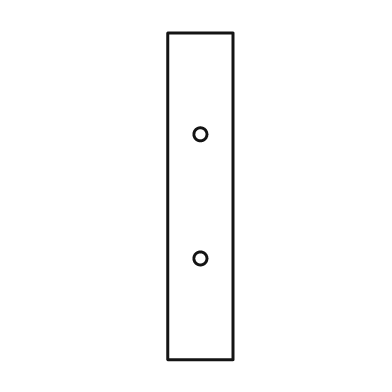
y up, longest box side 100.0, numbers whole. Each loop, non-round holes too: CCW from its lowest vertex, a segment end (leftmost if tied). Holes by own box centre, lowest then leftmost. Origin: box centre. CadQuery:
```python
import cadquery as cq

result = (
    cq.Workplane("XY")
    .moveTo(-10.0, -50.0)
    .lineTo(10.0, -50.0)
    .lineTo(10.0, 50.0)
    .lineTo(-10.0, 50.0)
    .close()
    .moveTo(0.0, -19.0)
    .circle(2.0)
    .moveTo(0.0, 19.0)
    .circle(2.0)
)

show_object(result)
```